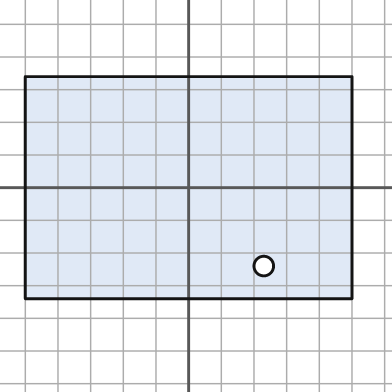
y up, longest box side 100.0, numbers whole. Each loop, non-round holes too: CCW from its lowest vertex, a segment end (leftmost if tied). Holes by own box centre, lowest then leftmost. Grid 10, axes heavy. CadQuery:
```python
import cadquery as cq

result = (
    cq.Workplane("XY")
    .moveTo(-50.0, -34.0)
    .lineTo(50.0, -34.0)
    .lineTo(50.0, 34.0)
    .lineTo(-50.0, 34.0)
    .close()
    .moveTo(23.0, -24.0)
    .circle(3.0)
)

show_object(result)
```